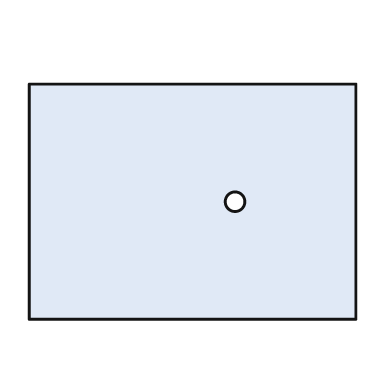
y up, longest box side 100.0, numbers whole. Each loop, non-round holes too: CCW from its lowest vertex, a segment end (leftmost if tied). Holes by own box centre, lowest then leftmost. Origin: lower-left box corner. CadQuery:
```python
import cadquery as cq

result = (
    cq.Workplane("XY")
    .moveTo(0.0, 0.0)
    .lineTo(100.0, 0.0)
    .lineTo(100.0, 72.0)
    .lineTo(0.0, 72.0)
    .close()
    .moveTo(63.0, 36.0)
    .circle(3.0)
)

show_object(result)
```